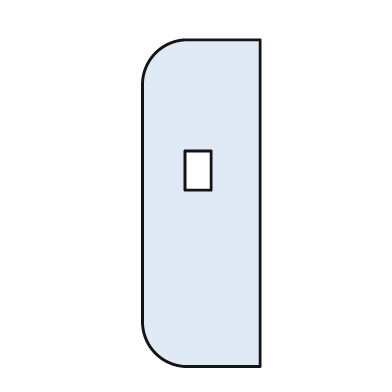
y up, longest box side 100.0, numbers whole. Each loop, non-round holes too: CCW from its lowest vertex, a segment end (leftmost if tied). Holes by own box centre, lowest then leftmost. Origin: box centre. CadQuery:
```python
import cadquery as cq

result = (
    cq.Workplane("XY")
    .moveTo(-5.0, -50.0)
    .lineTo(18.0, -50.0)
    .lineTo(18.0, 50.0)
    .lineTo(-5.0, 50.0)
    .threePointArc((-14.0, 46.0), (-18.0, 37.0))
    .lineTo(-18.0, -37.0)
    .threePointArc((-14.0, -46.0), (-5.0, -50.0))
    .close()
    .moveTo(-5.0, 4.0)
    .lineTo(3.0, 4.0)
    .lineTo(3.0, 16.0)
    .lineTo(-5.0, 16.0)
    .close()
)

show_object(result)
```